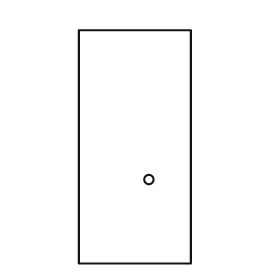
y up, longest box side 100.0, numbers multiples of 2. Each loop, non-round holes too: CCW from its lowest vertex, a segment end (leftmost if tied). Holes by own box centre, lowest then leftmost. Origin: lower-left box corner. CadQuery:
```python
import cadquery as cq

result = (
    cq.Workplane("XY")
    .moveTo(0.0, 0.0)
    .lineTo(48.0, 0.0)
    .lineTo(48.0, 100.0)
    .lineTo(0.0, 100.0)
    .close()
    .moveTo(30.0, 36.0)
    .circle(2.0)
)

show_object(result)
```